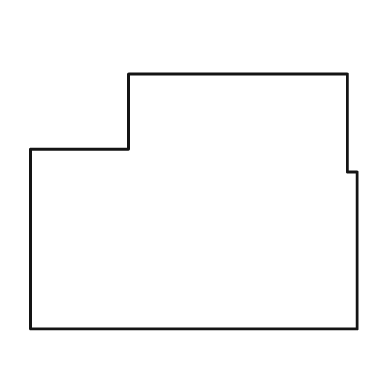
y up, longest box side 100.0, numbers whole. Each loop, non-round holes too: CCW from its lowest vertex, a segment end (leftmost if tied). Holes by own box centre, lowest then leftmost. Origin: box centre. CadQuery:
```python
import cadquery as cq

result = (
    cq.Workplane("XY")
    .moveTo(-50.0, -39.0)
    .lineTo(50.0, -39.0)
    .lineTo(50.0, 9.0)
    .lineTo(47.0, 9.0)
    .lineTo(47.0, 39.0)
    .lineTo(-20.0, 39.0)
    .lineTo(-20.0, 16.0)
    .lineTo(-50.0, 16.0)
    .close()
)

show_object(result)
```